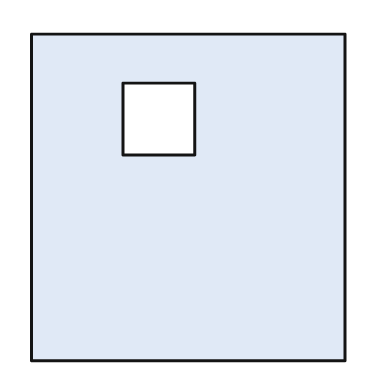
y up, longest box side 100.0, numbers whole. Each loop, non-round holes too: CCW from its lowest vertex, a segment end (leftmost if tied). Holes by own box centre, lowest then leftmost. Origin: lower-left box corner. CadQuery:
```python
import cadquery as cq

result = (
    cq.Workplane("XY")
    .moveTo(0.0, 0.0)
    .lineTo(96.0, 0.0)
    .lineTo(96.0, 100.0)
    .lineTo(0.0, 100.0)
    .close()
    .moveTo(28.0, 63.0)
    .lineTo(50.0, 63.0)
    .lineTo(50.0, 85.0)
    .lineTo(28.0, 85.0)
    .close()
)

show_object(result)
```